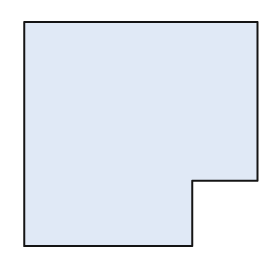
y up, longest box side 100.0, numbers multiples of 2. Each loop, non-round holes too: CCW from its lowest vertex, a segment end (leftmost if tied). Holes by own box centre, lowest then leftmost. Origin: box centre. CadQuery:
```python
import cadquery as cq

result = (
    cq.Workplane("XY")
    .moveTo(-50.0, -48.0)
    .lineTo(22.0, -48.0)
    .lineTo(22.0, -20.0)
    .lineTo(50.0, -20.0)
    .lineTo(50.0, 48.0)
    .lineTo(-50.0, 48.0)
    .close()
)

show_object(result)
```